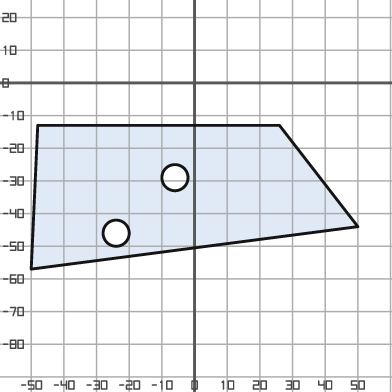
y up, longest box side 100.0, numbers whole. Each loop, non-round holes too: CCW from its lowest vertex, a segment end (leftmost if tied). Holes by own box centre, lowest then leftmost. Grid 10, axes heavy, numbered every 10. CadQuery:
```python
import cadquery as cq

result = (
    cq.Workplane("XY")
    .moveTo(-50.0, -57.0)
    .lineTo(50.0, -44.0)
    .lineTo(26.0, -13.0)
    .lineTo(-48.0, -13.0)
    .close()
    .moveTo(-24.0, -46.0)
    .circle(4.0)
    .moveTo(-6.0, -29.0)
    .circle(4.0)
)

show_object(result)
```